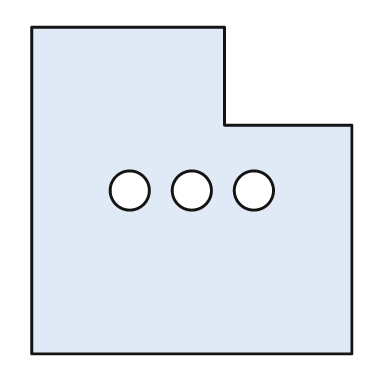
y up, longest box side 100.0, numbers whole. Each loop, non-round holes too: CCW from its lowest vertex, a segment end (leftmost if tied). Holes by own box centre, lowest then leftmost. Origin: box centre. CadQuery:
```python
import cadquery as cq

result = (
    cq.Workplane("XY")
    .moveTo(-49.0, -50.0)
    .lineTo(49.0, -50.0)
    .lineTo(49.0, 20.0)
    .lineTo(10.0, 20.0)
    .lineTo(10.0, 50.0)
    .lineTo(-49.0, 50.0)
    .close()
    .moveTo(-19.0, 0.0)
    .circle(6.0)
    .moveTo(0.0, 0.0)
    .circle(6.0)
    .moveTo(19.0, 0.0)
    .circle(6.0)
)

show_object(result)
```